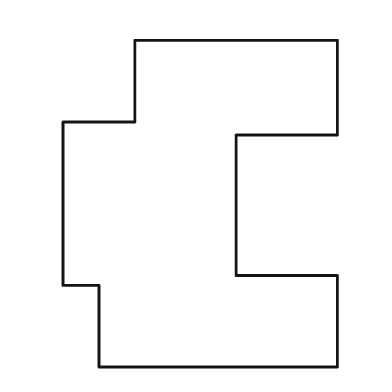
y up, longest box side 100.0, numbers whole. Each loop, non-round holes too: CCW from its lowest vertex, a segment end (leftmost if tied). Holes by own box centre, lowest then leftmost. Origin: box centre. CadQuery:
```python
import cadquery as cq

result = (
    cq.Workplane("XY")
    .moveTo(-31.0, -50.0)
    .lineTo(42.0, -50.0)
    .lineTo(42.0, -22.0)
    .lineTo(11.0, -22.0)
    .lineTo(11.0, 21.0)
    .lineTo(42.0, 21.0)
    .lineTo(42.0, 50.0)
    .lineTo(-20.0, 50.0)
    .lineTo(-20.0, 25.0)
    .lineTo(-42.0, 25.0)
    .lineTo(-42.0, -25.0)
    .lineTo(-31.0, -25.0)
    .close()
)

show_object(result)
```